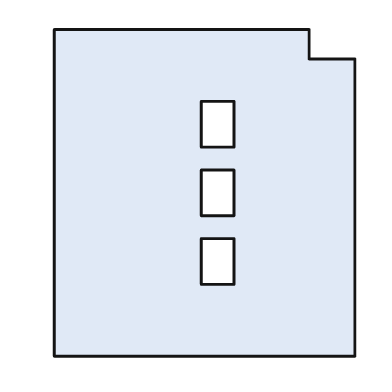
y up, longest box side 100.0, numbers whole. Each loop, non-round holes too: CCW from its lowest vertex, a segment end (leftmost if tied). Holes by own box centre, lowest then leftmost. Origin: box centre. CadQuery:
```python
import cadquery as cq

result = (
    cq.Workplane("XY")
    .moveTo(-46.0, -50.0)
    .lineTo(46.0, -50.0)
    .lineTo(46.0, 41.0)
    .lineTo(32.0, 41.0)
    .lineTo(32.0, 50.0)
    .lineTo(-46.0, 50.0)
    .close()
    .moveTo(-1.0, -28.0)
    .lineTo(9.0, -28.0)
    .lineTo(9.0, -14.0)
    .lineTo(-1.0, -14.0)
    .close()
    .moveTo(-1.0, -7.0)
    .lineTo(9.0, -7.0)
    .lineTo(9.0, 7.0)
    .lineTo(-1.0, 7.0)
    .close()
    .moveTo(-1.0, 14.0)
    .lineTo(9.0, 14.0)
    .lineTo(9.0, 28.0)
    .lineTo(-1.0, 28.0)
    .close()
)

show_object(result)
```